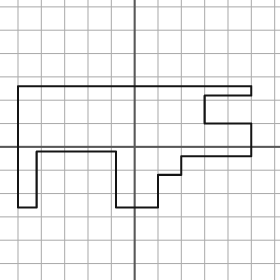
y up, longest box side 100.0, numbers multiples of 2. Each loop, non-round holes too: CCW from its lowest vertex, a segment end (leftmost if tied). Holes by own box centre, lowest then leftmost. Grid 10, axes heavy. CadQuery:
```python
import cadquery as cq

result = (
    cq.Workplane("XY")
    .moveTo(-50.0, -26.0)
    .lineTo(-42.0, -26.0)
    .lineTo(-42.0, -2.0)
    .lineTo(-8.0, -2.0)
    .lineTo(-8.0, -26.0)
    .lineTo(10.0, -26.0)
    .lineTo(10.0, -12.0)
    .lineTo(20.0, -12.0)
    .lineTo(20.0, -4.0)
    .lineTo(50.0, -4.0)
    .lineTo(50.0, 10.0)
    .lineTo(30.0, 10.0)
    .lineTo(30.0, 22.0)
    .lineTo(50.0, 22.0)
    .lineTo(50.0, 26.0)
    .lineTo(-50.0, 26.0)
    .close()
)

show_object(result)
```